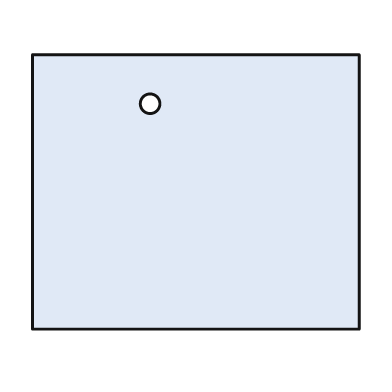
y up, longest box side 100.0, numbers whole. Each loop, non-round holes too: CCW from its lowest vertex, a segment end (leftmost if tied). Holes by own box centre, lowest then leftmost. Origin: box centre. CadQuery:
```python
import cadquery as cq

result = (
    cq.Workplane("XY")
    .moveTo(-50.0, -42.0)
    .lineTo(50.0, -42.0)
    .lineTo(50.0, 42.0)
    .lineTo(-50.0, 42.0)
    .close()
    .moveTo(-14.0, 27.0)
    .circle(3.0)
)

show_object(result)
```